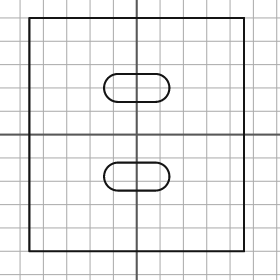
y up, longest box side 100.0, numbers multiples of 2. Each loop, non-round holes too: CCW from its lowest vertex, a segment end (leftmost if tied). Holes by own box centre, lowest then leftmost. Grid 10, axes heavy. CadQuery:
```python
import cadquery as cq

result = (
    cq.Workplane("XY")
    .moveTo(-46.0, -50.0)
    .lineTo(46.0, -50.0)
    .lineTo(46.0, 50.0)
    .lineTo(-46.0, 50.0)
    .close()
    .moveTo(-8.0, -24.0)
    .lineTo(8.0, -24.0)
    .threePointArc((14.0, -18.0), (8.0, -12.0))
    .lineTo(-8.0, -12.0)
    .threePointArc((-14.0, -18.0), (-8.0, -24.0))
    .close()
    .moveTo(-8.0, 14.0)
    .lineTo(8.0, 14.0)
    .threePointArc((14.0, 20.0), (8.0, 26.0))
    .lineTo(-8.0, 26.0)
    .threePointArc((-14.0, 20.0), (-8.0, 14.0))
    .close()
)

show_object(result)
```